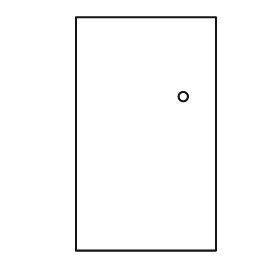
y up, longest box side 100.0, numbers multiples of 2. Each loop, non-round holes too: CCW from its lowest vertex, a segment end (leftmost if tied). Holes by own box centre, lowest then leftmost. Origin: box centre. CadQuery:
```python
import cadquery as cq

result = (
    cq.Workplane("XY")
    .moveTo(-30.0, -50.0)
    .lineTo(30.0, -50.0)
    .lineTo(30.0, 50.0)
    .lineTo(-30.0, 50.0)
    .close()
    .moveTo(16.0, 16.0)
    .circle(2.0)
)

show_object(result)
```